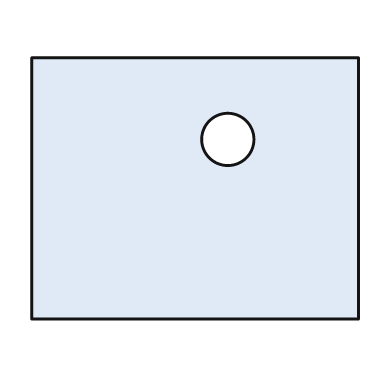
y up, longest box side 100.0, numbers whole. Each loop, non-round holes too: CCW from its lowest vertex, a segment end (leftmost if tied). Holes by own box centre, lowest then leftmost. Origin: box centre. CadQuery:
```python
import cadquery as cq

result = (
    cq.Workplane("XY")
    .moveTo(-50.0, -40.0)
    .lineTo(50.0, -40.0)
    .lineTo(50.0, 40.0)
    .lineTo(-50.0, 40.0)
    .close()
    .moveTo(10.0, 15.0)
    .circle(8.0)
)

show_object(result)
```